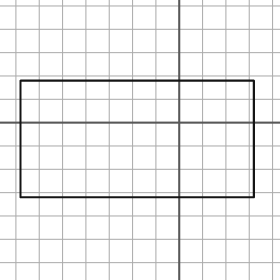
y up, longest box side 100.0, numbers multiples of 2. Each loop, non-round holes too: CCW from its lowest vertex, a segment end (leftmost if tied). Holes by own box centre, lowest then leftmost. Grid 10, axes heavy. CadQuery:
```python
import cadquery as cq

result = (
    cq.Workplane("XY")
    .moveTo(-68.0, -32.0)
    .lineTo(32.0, -32.0)
    .lineTo(32.0, 18.0)
    .lineTo(-68.0, 18.0)
    .close()
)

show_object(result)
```